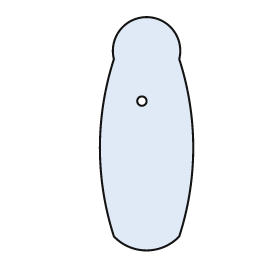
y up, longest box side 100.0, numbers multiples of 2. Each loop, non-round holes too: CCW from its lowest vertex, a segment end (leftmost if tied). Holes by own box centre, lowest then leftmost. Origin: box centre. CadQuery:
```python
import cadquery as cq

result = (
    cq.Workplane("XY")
    .moveTo(-14.0, -44.0)
    .threePointArc((0.0, -50.0), (14.0, -44.0))
    .threePointArc((20.0, -6.0), (14.0, 32.0))
    .threePointArc((0.0, 50.0), (-14.0, 32.0))
    .threePointArc((-20.0, -6.0), (-14.0, -44.0))
    .close()
    .moveTo(-2.0, 14.0)
    .circle(2.0)
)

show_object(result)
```